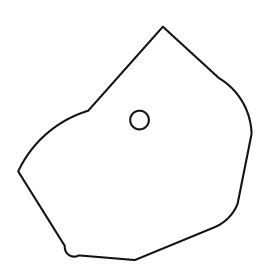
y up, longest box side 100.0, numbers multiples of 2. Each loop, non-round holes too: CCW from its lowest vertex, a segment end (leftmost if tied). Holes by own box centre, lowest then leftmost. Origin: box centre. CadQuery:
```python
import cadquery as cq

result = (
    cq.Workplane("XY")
    .moveTo(0.0, -50.0)
    .lineTo(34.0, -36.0)
    .threePointArc((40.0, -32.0), (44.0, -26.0))
    .lineTo(50.0, 4.0)
    .threePointArc((46.0, 18.0), (36.0, 28.0))
    .lineTo(12.0, 50.0)
    .lineTo(-20.0, 14.0)
    .threePointArc((-38.0, 4.0), (-50.0, -12.0))
    .lineTo(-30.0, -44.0)
    .threePointArc((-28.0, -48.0), (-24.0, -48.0))
    .close()
    .moveTo(2.0, 10.0)
    .circle(4.0)
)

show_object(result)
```